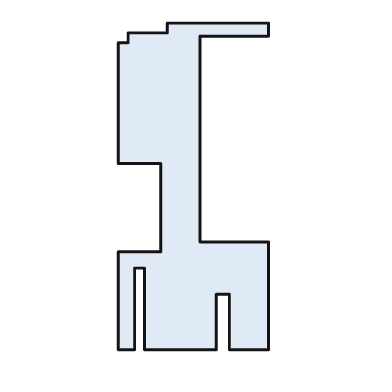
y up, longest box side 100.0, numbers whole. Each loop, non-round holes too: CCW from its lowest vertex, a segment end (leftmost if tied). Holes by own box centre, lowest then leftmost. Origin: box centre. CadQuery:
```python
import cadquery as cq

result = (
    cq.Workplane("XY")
    .moveTo(-23.0, -50.0)
    .lineTo(-18.0, -50.0)
    .lineTo(-18.0, -25.0)
    .lineTo(-15.0, -25.0)
    .lineTo(-15.0, -50.0)
    .lineTo(7.0, -50.0)
    .lineTo(7.0, -33.0)
    .lineTo(11.0, -33.0)
    .lineTo(11.0, -50.0)
    .lineTo(23.0, -50.0)
    .lineTo(23.0, -17.0)
    .lineTo(2.0, -17.0)
    .lineTo(2.0, 46.0)
    .lineTo(23.0, 46.0)
    .lineTo(23.0, 50.0)
    .lineTo(-8.0, 50.0)
    .lineTo(-8.0, 47.0)
    .lineTo(-20.0, 47.0)
    .lineTo(-20.0, 44.0)
    .lineTo(-23.0, 44.0)
    .lineTo(-23.0, 7.0)
    .lineTo(-10.0, 7.0)
    .lineTo(-10.0, -20.0)
    .lineTo(-23.0, -20.0)
    .close()
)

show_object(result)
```